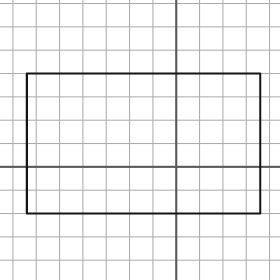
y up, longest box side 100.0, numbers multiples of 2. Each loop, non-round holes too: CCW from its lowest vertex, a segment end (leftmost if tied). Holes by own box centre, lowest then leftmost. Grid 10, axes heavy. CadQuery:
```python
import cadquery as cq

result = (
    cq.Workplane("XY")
    .moveTo(-64.0, -20.0)
    .lineTo(36.0, -20.0)
    .lineTo(36.0, 40.0)
    .lineTo(-64.0, 40.0)
    .close()
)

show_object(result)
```